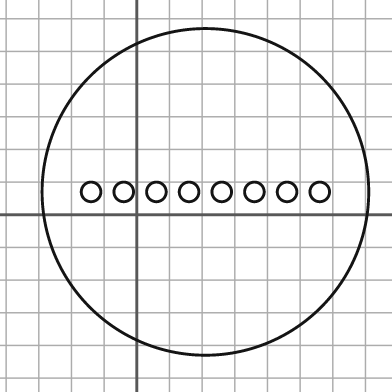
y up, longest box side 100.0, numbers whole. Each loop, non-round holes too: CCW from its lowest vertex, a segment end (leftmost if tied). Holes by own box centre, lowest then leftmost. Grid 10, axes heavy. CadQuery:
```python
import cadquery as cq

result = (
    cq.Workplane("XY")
    .moveTo(21.0, 7.0)
    .circle(50.0)
    .moveTo(-14.0, 7.0)
    .circle(3.0)
    .moveTo(-4.0, 7.0)
    .circle(3.0)
    .moveTo(6.0, 7.0)
    .circle(3.0)
    .moveTo(16.0, 7.0)
    .circle(3.0)
    .moveTo(26.0, 7.0)
    .circle(3.0)
    .moveTo(36.0, 7.0)
    .circle(3.0)
    .moveTo(46.0, 7.0)
    .circle(3.0)
    .moveTo(56.0, 7.0)
    .circle(3.0)
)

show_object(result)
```